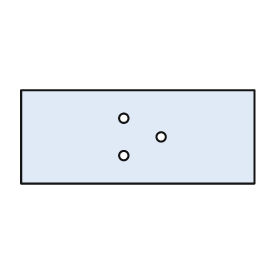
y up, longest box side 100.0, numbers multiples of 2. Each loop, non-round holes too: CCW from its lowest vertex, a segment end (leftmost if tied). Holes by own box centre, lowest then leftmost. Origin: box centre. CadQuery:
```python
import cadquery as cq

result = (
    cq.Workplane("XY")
    .moveTo(-50.0, -20.0)
    .lineTo(50.0, -20.0)
    .lineTo(50.0, 20.0)
    .lineTo(-50.0, 20.0)
    .close()
    .moveTo(-6.0, -8.0)
    .circle(2.0)
    .moveTo(10.0, 0.0)
    .circle(2.0)
    .moveTo(-6.0, 8.0)
    .circle(2.0)
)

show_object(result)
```